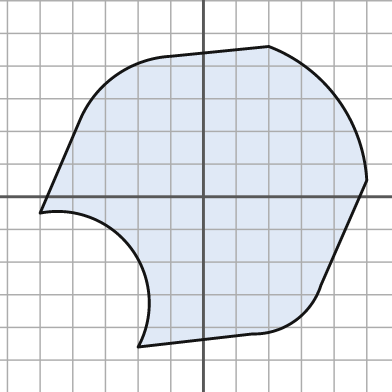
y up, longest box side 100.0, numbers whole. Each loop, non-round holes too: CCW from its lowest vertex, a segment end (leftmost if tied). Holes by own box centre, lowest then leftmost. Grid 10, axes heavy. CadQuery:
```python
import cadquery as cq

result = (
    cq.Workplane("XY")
    .moveTo(-20.0, -46.0)
    .lineTo(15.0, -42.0)
    .threePointArc((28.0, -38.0), (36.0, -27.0))
    .lineTo(50.0, 5.0)
    .threePointArc((41.0, 30.0), (20.0, 46.0))
    .lineTo(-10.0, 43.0)
    .threePointArc((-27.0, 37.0), (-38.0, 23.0))
    .lineTo(-50.0, -5.0)
    .threePointArc((-22.0, -16.0), (-20.0, -46.0))
    .close()
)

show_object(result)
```